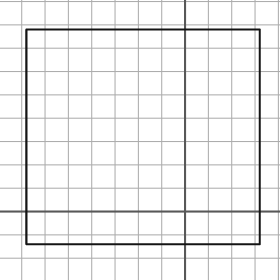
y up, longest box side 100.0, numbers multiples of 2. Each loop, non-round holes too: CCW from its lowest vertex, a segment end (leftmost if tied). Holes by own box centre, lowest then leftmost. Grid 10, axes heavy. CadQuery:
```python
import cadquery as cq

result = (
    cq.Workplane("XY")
    .moveTo(-68.0, -14.0)
    .lineTo(32.0, -14.0)
    .lineTo(32.0, 78.0)
    .lineTo(-68.0, 78.0)
    .close()
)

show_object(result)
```